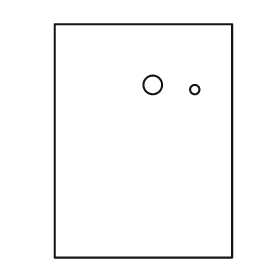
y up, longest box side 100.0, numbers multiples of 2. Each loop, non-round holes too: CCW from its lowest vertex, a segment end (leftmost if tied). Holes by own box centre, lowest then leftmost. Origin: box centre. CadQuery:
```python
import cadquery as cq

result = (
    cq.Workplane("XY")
    .moveTo(-38.0, -50.0)
    .lineTo(38.0, -50.0)
    .lineTo(38.0, 50.0)
    .lineTo(-38.0, 50.0)
    .close()
    .moveTo(22.0, 22.0)
    .circle(2.0)
    .moveTo(4.0, 24.0)
    .circle(4.0)
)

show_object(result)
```